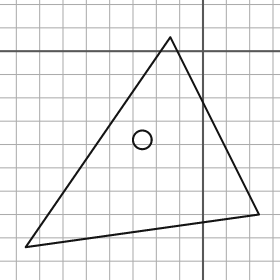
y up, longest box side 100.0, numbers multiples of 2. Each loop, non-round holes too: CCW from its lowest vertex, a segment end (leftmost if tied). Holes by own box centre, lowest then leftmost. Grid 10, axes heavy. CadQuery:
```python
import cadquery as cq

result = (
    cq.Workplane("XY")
    .moveTo(-76.0, -84.0)
    .lineTo(24.0, -70.0)
    .lineTo(-14.0, 6.0)
    .close()
    .moveTo(-26.0, -38.0)
    .circle(4.0)
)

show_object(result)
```